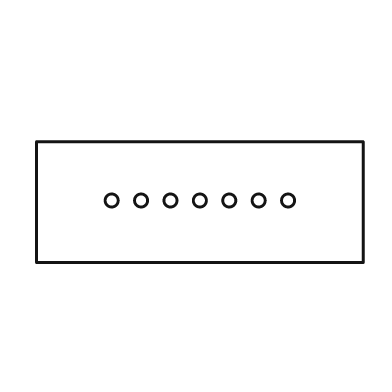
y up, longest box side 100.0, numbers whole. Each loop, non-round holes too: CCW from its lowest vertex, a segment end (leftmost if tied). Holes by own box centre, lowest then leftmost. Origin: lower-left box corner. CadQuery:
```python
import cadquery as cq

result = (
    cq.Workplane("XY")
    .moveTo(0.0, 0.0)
    .lineTo(100.0, 0.0)
    .lineTo(100.0, 37.0)
    .lineTo(0.0, 37.0)
    .close()
    .moveTo(23.0, 19.0)
    .circle(2.0)
    .moveTo(32.0, 19.0)
    .circle(2.0)
    .moveTo(41.0, 19.0)
    .circle(2.0)
    .moveTo(50.0, 19.0)
    .circle(2.0)
    .moveTo(59.0, 19.0)
    .circle(2.0)
    .moveTo(68.0, 19.0)
    .circle(2.0)
    .moveTo(77.0, 19.0)
    .circle(2.0)
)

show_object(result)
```